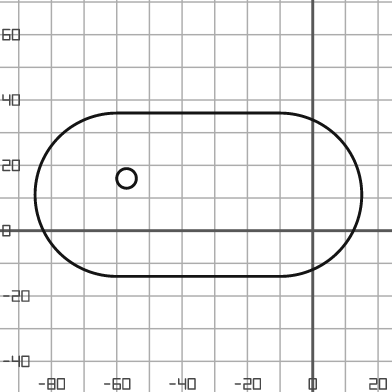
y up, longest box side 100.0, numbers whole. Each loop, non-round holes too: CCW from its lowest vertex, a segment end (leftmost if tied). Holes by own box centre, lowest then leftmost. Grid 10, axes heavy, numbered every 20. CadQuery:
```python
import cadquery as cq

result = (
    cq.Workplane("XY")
    .moveTo(-60.0, -14.0)
    .lineTo(-10.0, -14.0)
    .threePointArc((15.0, 11.0), (-10.0, 36.0))
    .lineTo(-60.0, 36.0)
    .threePointArc((-85.0, 11.0), (-60.0, -14.0))
    .close()
    .moveTo(-57.0, 16.0)
    .circle(3.0)
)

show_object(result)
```